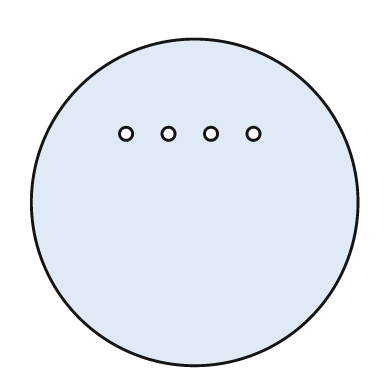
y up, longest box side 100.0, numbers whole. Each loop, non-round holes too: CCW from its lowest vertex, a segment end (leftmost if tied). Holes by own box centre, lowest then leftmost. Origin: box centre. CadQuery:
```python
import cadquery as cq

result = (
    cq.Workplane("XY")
    .moveTo(0.0, 0.0)
    .circle(50.0)
    .moveTo(-21.0, 21.0)
    .circle(2.0)
    .moveTo(-8.0, 21.0)
    .circle(2.0)
    .moveTo(5.0, 21.0)
    .circle(2.0)
    .moveTo(18.0, 21.0)
    .circle(2.0)
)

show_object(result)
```